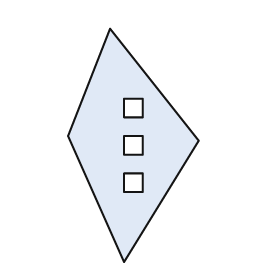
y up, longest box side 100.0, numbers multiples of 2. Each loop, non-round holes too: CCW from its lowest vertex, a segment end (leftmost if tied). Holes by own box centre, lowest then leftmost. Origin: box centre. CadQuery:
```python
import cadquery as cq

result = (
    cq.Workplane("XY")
    .moveTo(-4.0, -50.0)
    .lineTo(28.0, 2.0)
    .lineTo(-10.0, 50.0)
    .lineTo(-28.0, 4.0)
    .close()
    .moveTo(-4.0, -20.0)
    .lineTo(4.0, -20.0)
    .lineTo(4.0, -12.0)
    .lineTo(-4.0, -12.0)
    .close()
    .moveTo(-4.0, -4.0)
    .lineTo(4.0, -4.0)
    .lineTo(4.0, 4.0)
    .lineTo(-4.0, 4.0)
    .close()
    .moveTo(-4.0, 12.0)
    .lineTo(4.0, 12.0)
    .lineTo(4.0, 20.0)
    .lineTo(-4.0, 20.0)
    .close()
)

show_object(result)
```